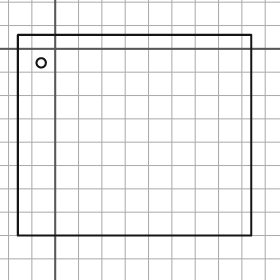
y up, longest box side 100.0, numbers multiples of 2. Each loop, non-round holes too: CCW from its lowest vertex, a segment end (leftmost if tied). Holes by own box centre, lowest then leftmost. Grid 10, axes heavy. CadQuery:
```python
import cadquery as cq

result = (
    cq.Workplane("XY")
    .moveTo(-16.0, -80.0)
    .lineTo(84.0, -80.0)
    .lineTo(84.0, 6.0)
    .lineTo(-16.0, 6.0)
    .close()
    .moveTo(-6.0, -6.0)
    .circle(2.0)
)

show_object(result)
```